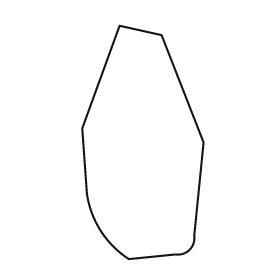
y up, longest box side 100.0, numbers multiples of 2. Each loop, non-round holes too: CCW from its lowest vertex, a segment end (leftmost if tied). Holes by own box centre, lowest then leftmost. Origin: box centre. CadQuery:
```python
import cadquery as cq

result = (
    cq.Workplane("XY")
    .moveTo(-6.0, -50.0)
    .lineTo(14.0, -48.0)
    .threePointArc((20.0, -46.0), (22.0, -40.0))
    .lineTo(26.0, 0.0)
    .lineTo(8.0, 46.0)
    .lineTo(-10.0, 50.0)
    .lineTo(-26.0, 6.0)
    .lineTo(-24.0, -22.0)
    .threePointArc((-18.0, -38.0), (-6.0, -50.0))
    .close()
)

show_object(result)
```